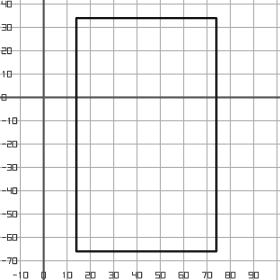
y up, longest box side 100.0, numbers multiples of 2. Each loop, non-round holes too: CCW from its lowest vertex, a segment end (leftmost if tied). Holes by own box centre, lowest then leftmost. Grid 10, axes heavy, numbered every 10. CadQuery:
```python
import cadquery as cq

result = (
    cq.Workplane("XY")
    .moveTo(14.0, -66.0)
    .lineTo(74.0, -66.0)
    .lineTo(74.0, 34.0)
    .lineTo(14.0, 34.0)
    .close()
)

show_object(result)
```